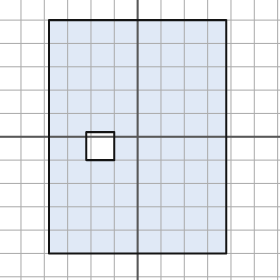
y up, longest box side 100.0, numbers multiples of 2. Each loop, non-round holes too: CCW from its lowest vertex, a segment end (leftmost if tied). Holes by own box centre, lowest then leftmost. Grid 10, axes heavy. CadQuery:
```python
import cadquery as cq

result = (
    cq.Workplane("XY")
    .moveTo(-38.0, -50.0)
    .lineTo(38.0, -50.0)
    .lineTo(38.0, 50.0)
    .lineTo(-38.0, 50.0)
    .close()
    .moveTo(-22.0, -10.0)
    .lineTo(-10.0, -10.0)
    .lineTo(-10.0, 2.0)
    .lineTo(-22.0, 2.0)
    .close()
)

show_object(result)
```